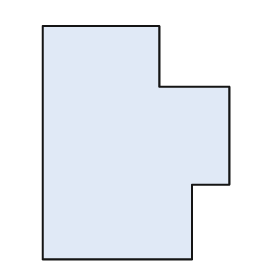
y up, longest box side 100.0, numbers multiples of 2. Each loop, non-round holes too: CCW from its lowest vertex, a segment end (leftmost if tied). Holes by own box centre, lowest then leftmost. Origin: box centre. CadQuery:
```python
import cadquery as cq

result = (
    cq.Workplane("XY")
    .moveTo(-40.0, -50.0)
    .lineTo(24.0, -50.0)
    .lineTo(24.0, -18.0)
    .lineTo(40.0, -18.0)
    .lineTo(40.0, 24.0)
    .lineTo(10.0, 24.0)
    .lineTo(10.0, 50.0)
    .lineTo(-40.0, 50.0)
    .close()
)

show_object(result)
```